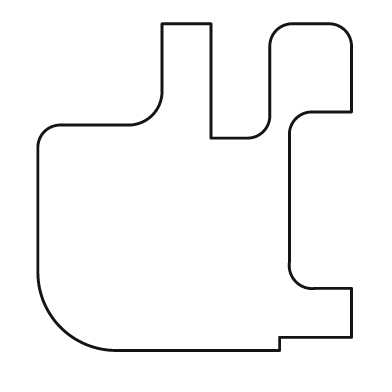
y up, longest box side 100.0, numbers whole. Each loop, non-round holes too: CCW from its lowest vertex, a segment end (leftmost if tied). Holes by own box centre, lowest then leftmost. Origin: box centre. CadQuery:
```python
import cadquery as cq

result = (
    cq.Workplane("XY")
    .moveTo(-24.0, -50.0)
    .lineTo(26.0, -50.0)
    .lineTo(26.0, -46.0)
    .lineTo(48.0, -46.0)
    .lineTo(48.0, -31.0)
    .lineTo(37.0, -31.0)
    .threePointArc((31.0, -29.0), (29.0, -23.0))
    .lineTo(29.0, 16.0)
    .threePointArc((31.0, 21.0), (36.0, 23.0))
    .lineTo(48.0, 23.0)
    .lineTo(48.0, 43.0)
    .threePointArc((46.0, 48.0), (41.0, 50.0))
    .lineTo(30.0, 50.0)
    .threePointArc((25.0, 48.0), (23.0, 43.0))
    .lineTo(23.0, 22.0)
    .threePointArc((21.0, 17.0), (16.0, 15.0))
    .lineTo(5.0, 15.0)
    .lineTo(5.0, 50.0)
    .lineTo(-10.0, 50.0)
    .lineTo(-10.0, 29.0)
    .threePointArc((-13.0, 22.0), (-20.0, 19.0))
    .lineTo(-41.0, 19.0)
    .threePointArc((-46.0, 17.0), (-48.0, 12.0))
    .lineTo(-48.0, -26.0)
    .threePointArc((-41.0, -43.0), (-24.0, -50.0))
    .close()
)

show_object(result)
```